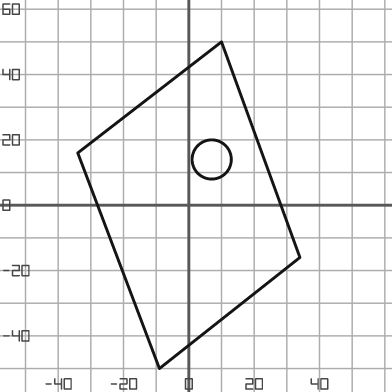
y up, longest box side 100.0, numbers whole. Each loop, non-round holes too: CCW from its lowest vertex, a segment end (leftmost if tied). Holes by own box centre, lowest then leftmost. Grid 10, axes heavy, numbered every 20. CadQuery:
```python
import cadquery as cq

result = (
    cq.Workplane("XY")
    .moveTo(-9.0, -50.0)
    .lineTo(34.0, -16.0)
    .lineTo(10.0, 50.0)
    .lineTo(-34.0, 16.0)
    .close()
    .moveTo(7.0, 14.0)
    .circle(6.0)
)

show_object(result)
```